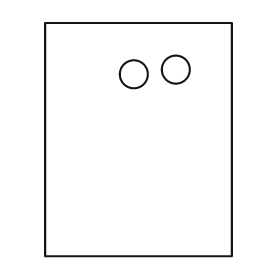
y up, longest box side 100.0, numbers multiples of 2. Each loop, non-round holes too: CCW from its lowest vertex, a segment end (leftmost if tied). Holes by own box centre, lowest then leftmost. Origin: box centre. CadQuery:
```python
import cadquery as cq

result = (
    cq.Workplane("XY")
    .moveTo(-40.0, -50.0)
    .lineTo(40.0, -50.0)
    .lineTo(40.0, 50.0)
    .lineTo(-40.0, 50.0)
    .close()
    .moveTo(-2.0, 28.0)
    .circle(6.0)
    .moveTo(16.0, 30.0)
    .circle(6.0)
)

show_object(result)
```